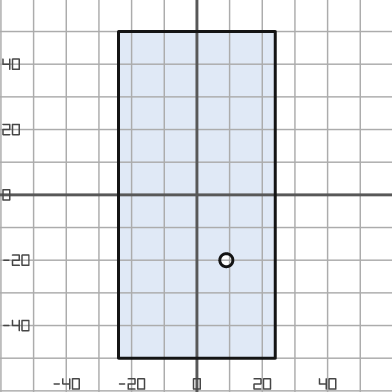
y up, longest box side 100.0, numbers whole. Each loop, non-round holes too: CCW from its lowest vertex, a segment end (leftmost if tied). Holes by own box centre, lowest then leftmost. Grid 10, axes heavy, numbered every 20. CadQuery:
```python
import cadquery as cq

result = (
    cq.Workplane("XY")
    .moveTo(-24.0, -50.0)
    .lineTo(24.0, -50.0)
    .lineTo(24.0, 50.0)
    .lineTo(-24.0, 50.0)
    .close()
    .moveTo(9.0, -20.0)
    .circle(2.0)
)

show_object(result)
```